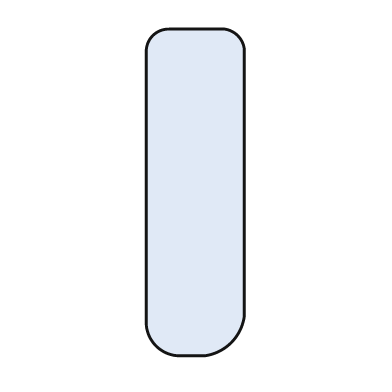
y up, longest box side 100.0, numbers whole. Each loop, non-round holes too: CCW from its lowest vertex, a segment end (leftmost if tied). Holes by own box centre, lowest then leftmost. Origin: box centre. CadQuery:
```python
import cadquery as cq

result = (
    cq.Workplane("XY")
    .moveTo(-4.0, -50.0)
    .lineTo(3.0, -50.0)
    .threePointArc((11.0, -46.0), (15.0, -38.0))
    .lineTo(15.0, 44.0)
    .threePointArc((13.0, 48.0), (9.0, 50.0))
    .lineTo(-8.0, 50.0)
    .threePointArc((-13.0, 48.0), (-15.0, 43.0))
    .lineTo(-15.0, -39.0)
    .threePointArc((-12.0, -47.0), (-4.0, -50.0))
    .close()
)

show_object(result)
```